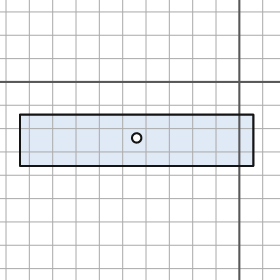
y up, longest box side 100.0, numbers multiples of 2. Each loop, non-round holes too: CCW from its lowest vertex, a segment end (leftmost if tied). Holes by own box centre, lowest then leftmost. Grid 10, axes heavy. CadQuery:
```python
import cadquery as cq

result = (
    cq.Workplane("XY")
    .moveTo(-94.0, -36.0)
    .lineTo(6.0, -36.0)
    .lineTo(6.0, -14.0)
    .lineTo(-94.0, -14.0)
    .close()
    .moveTo(-44.0, -24.0)
    .circle(2.0)
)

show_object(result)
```